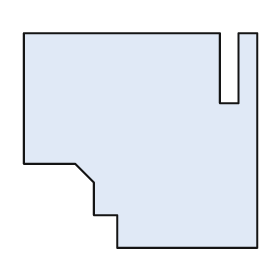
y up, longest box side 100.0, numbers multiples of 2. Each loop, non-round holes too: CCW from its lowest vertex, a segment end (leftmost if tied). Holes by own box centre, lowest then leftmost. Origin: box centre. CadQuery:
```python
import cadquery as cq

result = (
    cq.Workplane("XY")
    .moveTo(-10.0, -46.0)
    .lineTo(50.0, -46.0)
    .lineTo(50.0, 46.0)
    .lineTo(42.0, 46.0)
    .lineTo(42.0, 16.0)
    .lineTo(34.0, 16.0)
    .lineTo(34.0, 46.0)
    .lineTo(-50.0, 46.0)
    .lineTo(-50.0, -10.0)
    .lineTo(-28.0, -10.0)
    .lineTo(-20.0, -18.0)
    .lineTo(-20.0, -32.0)
    .lineTo(-10.0, -32.0)
    .close()
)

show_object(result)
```